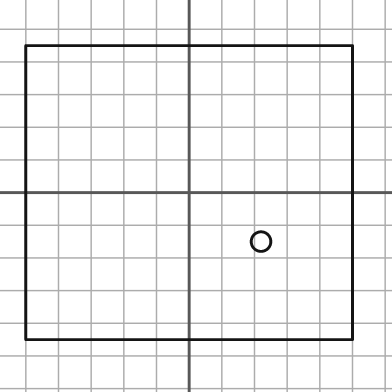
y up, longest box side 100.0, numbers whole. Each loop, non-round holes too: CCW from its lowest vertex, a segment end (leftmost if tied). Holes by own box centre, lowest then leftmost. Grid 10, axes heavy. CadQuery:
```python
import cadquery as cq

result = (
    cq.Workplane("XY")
    .moveTo(-50.0, -45.0)
    .lineTo(50.0, -45.0)
    .lineTo(50.0, 45.0)
    .lineTo(-50.0, 45.0)
    .close()
    .moveTo(22.0, -15.0)
    .circle(3.0)
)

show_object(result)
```